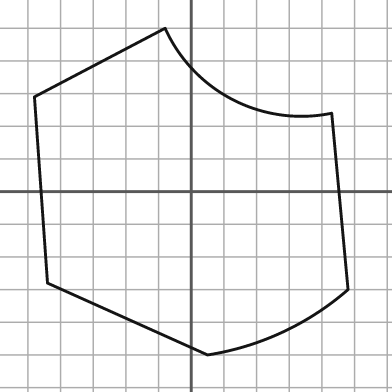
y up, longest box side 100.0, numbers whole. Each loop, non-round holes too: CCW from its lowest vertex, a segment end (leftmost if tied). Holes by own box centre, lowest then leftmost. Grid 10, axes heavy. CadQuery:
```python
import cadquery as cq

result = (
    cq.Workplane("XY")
    .moveTo(5.0, -50.0)
    .threePointArc((28.0, -43.0), (48.0, -30.0))
    .lineTo(43.0, 24.0)
    .threePointArc((13.0, 28.0), (-8.0, 50.0))
    .lineTo(-48.0, 29.0)
    .lineTo(-44.0, -28.0)
    .close()
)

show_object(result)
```